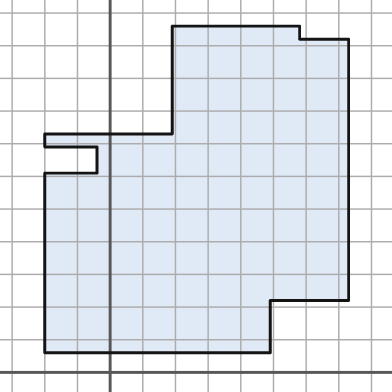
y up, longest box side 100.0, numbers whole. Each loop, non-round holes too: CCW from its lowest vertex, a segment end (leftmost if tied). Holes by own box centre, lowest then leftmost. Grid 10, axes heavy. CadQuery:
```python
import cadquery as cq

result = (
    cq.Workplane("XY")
    .moveTo(-20.0, 6.0)
    .lineTo(49.0, 6.0)
    .lineTo(49.0, 22.0)
    .lineTo(73.0, 22.0)
    .lineTo(73.0, 102.0)
    .lineTo(58.0, 102.0)
    .lineTo(58.0, 106.0)
    .lineTo(19.0, 106.0)
    .lineTo(19.0, 73.0)
    .lineTo(-20.0, 73.0)
    .lineTo(-20.0, 69.0)
    .lineTo(-4.0, 69.0)
    .lineTo(-4.0, 61.0)
    .lineTo(-20.0, 61.0)
    .close()
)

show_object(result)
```